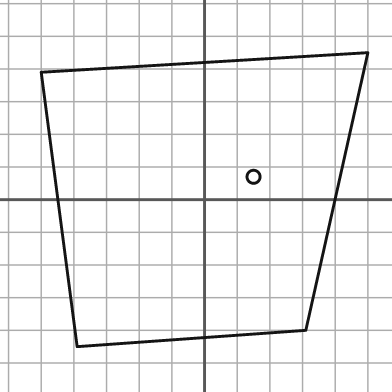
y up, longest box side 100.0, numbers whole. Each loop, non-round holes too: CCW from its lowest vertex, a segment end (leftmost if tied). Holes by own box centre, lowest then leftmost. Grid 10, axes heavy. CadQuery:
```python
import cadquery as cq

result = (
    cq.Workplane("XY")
    .moveTo(-39.0, -45.0)
    .lineTo(31.0, -40.0)
    .lineTo(50.0, 45.0)
    .lineTo(-50.0, 39.0)
    .close()
    .moveTo(15.0, 7.0)
    .circle(2.0)
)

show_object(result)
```